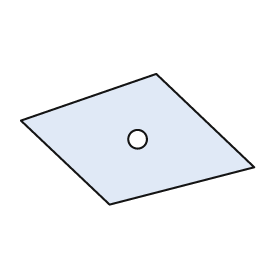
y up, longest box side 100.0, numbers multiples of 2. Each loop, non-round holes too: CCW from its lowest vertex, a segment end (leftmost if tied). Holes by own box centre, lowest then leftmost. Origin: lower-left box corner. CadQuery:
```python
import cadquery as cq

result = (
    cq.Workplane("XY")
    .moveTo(38.0, 0.0)
    .lineTo(100.0, 16.0)
    .lineTo(58.0, 56.0)
    .lineTo(0.0, 36.0)
    .close()
    .moveTo(50.0, 28.0)
    .circle(4.0)
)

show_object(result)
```